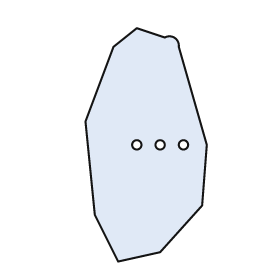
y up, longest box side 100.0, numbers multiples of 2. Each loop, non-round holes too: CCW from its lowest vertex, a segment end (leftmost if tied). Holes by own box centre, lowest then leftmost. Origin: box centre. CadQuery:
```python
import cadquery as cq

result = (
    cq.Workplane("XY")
    .moveTo(-12.0, -50.0)
    .lineTo(6.0, -46.0)
    .lineTo(24.0, -26.0)
    .lineTo(26.0, 0.0)
    .lineTo(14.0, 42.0)
    .threePointArc((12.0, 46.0), (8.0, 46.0))
    .lineTo(-4.0, 50.0)
    .lineTo(-14.0, 42.0)
    .lineTo(-26.0, 10.0)
    .lineTo(-22.0, -30.0)
    .close()
    .moveTo(-4.0, 0.0)
    .circle(2.0)
    .moveTo(6.0, 0.0)
    .circle(2.0)
    .moveTo(16.0, 0.0)
    .circle(2.0)
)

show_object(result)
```